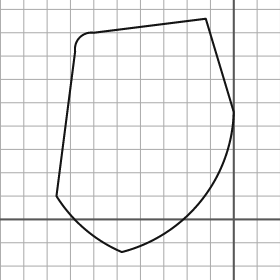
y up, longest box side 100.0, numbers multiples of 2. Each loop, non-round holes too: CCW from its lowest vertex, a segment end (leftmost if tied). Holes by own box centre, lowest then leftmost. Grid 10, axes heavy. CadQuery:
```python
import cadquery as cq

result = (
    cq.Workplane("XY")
    .moveTo(-48.0, -14.0)
    .threePointArc((-14.0, 8.0), (0.0, 46.0))
    .lineTo(-12.0, 86.0)
    .lineTo(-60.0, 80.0)
    .threePointArc((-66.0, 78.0), (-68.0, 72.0))
    .lineTo(-76.0, 10.0)
    .threePointArc((-64.0, -4.0), (-48.0, -14.0))
    .close()
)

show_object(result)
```